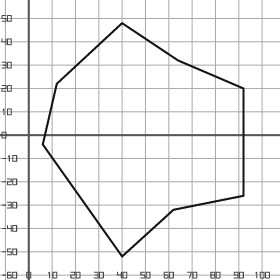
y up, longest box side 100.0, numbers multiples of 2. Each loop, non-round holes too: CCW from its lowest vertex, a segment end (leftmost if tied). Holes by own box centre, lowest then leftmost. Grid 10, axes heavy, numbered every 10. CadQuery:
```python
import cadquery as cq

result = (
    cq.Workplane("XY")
    .moveTo(40.0, -52.0)
    .lineTo(62.0, -32.0)
    .lineTo(92.0, -26.0)
    .lineTo(92.0, 20.0)
    .lineTo(64.0, 32.0)
    .lineTo(40.0, 48.0)
    .lineTo(12.0, 22.0)
    .lineTo(6.0, -4.0)
    .close()
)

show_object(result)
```